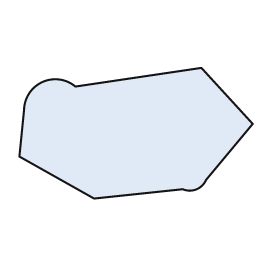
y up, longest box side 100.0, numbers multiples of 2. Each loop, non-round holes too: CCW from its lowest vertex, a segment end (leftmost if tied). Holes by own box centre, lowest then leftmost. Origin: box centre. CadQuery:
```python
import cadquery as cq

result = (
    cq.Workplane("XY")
    .moveTo(-18.0, -28.0)
    .lineTo(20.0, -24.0)
    .threePointArc((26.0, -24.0), (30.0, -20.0))
    .lineTo(50.0, 4.0)
    .lineTo(28.0, 28.0)
    .lineTo(-26.0, 20.0)
    .threePointArc((-40.0, 22.0), (-48.0, 10.0))
    .lineTo(-50.0, -10.0)
    .close()
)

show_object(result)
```